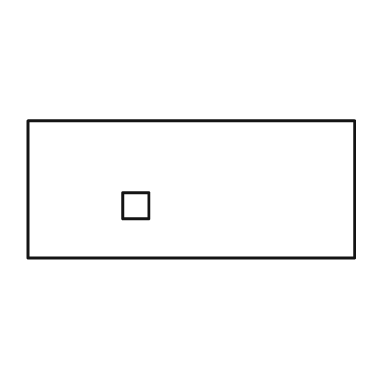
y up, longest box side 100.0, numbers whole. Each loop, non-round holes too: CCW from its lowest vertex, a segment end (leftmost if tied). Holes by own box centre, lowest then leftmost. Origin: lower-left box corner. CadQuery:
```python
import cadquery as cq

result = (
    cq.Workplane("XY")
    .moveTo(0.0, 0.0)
    .lineTo(100.0, 0.0)
    .lineTo(100.0, 42.0)
    .lineTo(0.0, 42.0)
    .close()
    .moveTo(29.0, 12.0)
    .lineTo(37.0, 12.0)
    .lineTo(37.0, 20.0)
    .lineTo(29.0, 20.0)
    .close()
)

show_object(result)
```